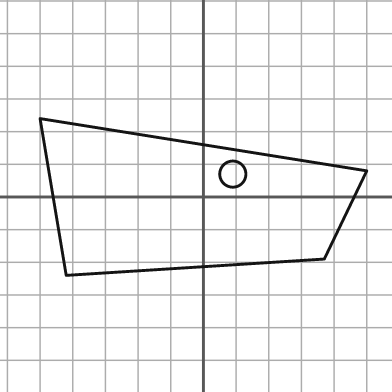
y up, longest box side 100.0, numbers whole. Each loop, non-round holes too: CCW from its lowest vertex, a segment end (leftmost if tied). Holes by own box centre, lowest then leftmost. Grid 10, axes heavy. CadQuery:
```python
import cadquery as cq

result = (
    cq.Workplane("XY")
    .moveTo(-42.0, -24.0)
    .lineTo(37.0, -19.0)
    .lineTo(50.0, 8.0)
    .lineTo(-50.0, 24.0)
    .close()
    .moveTo(9.0, 7.0)
    .circle(4.0)
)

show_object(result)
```